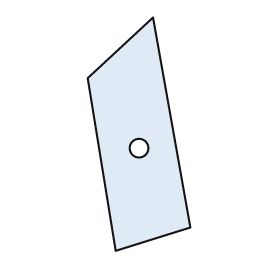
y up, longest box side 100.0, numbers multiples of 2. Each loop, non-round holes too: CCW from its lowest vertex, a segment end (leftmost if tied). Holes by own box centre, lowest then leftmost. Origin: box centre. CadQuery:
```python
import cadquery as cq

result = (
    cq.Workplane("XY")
    .moveTo(-10.0, -50.0)
    .lineTo(22.0, -40.0)
    .lineTo(6.0, 50.0)
    .lineTo(-22.0, 24.0)
    .close()
    .moveTo(0.0, -6.0)
    .circle(4.0)
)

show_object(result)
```